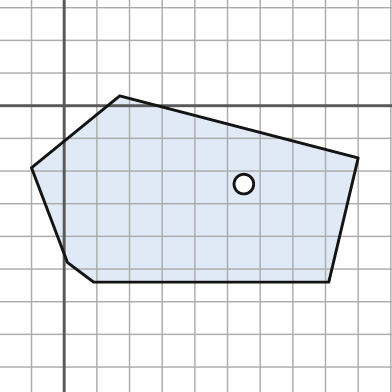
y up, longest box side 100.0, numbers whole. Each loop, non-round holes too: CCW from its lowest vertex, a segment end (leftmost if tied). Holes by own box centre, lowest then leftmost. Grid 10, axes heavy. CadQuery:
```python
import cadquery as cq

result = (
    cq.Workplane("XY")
    .moveTo(9.0, -54.0)
    .lineTo(81.0, -54.0)
    .lineTo(90.0, -16.0)
    .lineTo(17.0, 3.0)
    .lineTo(-10.0, -19.0)
    .lineTo(1.0, -48.0)
    .close()
    .moveTo(55.0, -24.0)
    .circle(3.0)
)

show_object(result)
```